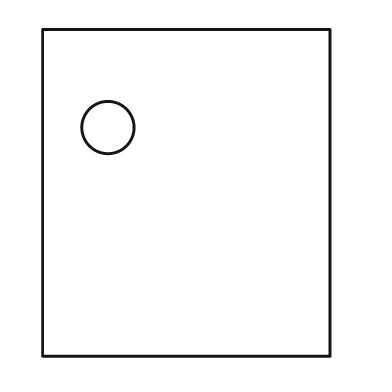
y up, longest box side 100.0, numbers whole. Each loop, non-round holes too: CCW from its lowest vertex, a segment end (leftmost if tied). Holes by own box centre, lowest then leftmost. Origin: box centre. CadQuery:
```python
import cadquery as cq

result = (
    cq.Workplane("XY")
    .moveTo(-44.0, -50.0)
    .lineTo(44.0, -50.0)
    .lineTo(44.0, 50.0)
    .lineTo(-44.0, 50.0)
    .close()
    .moveTo(-24.0, 20.0)
    .circle(8.0)
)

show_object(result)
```